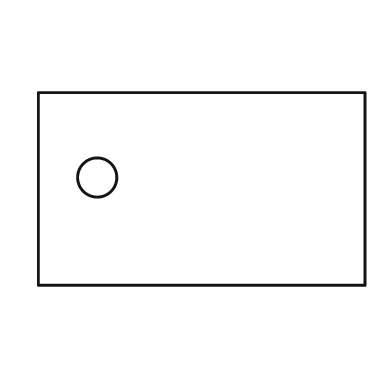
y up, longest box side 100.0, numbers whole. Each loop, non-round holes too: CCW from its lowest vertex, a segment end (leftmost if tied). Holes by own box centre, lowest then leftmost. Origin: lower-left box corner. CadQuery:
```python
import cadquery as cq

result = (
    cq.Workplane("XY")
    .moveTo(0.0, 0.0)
    .lineTo(100.0, 0.0)
    .lineTo(100.0, 59.0)
    .lineTo(0.0, 59.0)
    .close()
    .moveTo(18.0, 33.0)
    .circle(6.0)
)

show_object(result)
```